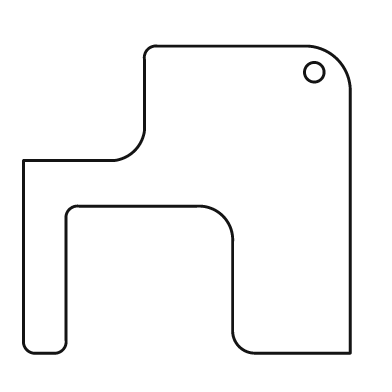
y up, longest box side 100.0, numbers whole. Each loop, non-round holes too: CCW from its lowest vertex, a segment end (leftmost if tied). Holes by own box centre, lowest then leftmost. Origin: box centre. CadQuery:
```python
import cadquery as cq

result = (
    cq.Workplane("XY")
    .moveTo(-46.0, -47.0)
    .lineTo(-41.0, -47.0)
    .threePointArc((-38.0, -46.0), (-37.0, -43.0))
    .lineTo(-37.0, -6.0)
    .threePointArc((-36.0, -3.0), (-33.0, -2.0))
    .lineTo(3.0, -2.0)
    .threePointArc((11.0, -5.0), (14.0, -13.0))
    .lineTo(14.0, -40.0)
    .threePointArc((16.0, -45.0), (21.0, -47.0))
    .lineTo(50.0, -47.0)
    .lineTo(50.0, 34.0)
    .threePointArc((46.0, 43.0), (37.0, 47.0))
    .lineTo(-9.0, 47.0)
    .threePointArc((-12.0, 46.0), (-13.0, 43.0))
    .lineTo(-13.0, 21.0)
    .threePointArc((-16.0, 15.0), (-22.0, 12.0))
    .lineTo(-50.0, 12.0)
    .lineTo(-50.0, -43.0)
    .threePointArc((-49.0, -46.0), (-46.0, -47.0))
    .close()
    .moveTo(39.0, 39.0)
    .circle(3.0)
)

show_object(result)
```